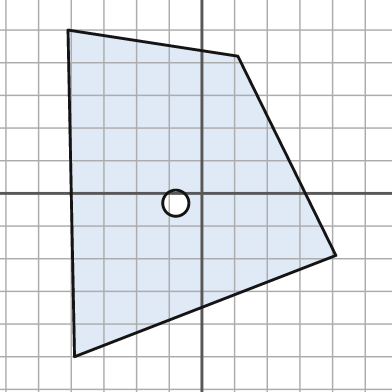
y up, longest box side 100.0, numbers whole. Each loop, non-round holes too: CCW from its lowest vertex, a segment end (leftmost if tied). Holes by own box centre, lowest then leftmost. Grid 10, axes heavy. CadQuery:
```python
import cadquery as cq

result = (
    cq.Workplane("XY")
    .moveTo(-39.0, -50.0)
    .lineTo(41.0, -19.0)
    .lineTo(11.0, 42.0)
    .lineTo(-41.0, 50.0)
    .close()
    .moveTo(-8.0, -3.0)
    .circle(4.0)
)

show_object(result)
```